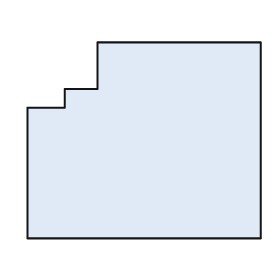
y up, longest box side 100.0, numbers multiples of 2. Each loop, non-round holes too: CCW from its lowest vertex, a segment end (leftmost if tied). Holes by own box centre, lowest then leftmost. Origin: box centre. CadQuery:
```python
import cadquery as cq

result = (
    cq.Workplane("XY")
    .moveTo(-50.0, -42.0)
    .lineTo(50.0, -42.0)
    .lineTo(50.0, 42.0)
    .lineTo(-20.0, 42.0)
    .lineTo(-20.0, 22.0)
    .lineTo(-34.0, 22.0)
    .lineTo(-34.0, 14.0)
    .lineTo(-50.0, 14.0)
    .close()
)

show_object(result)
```